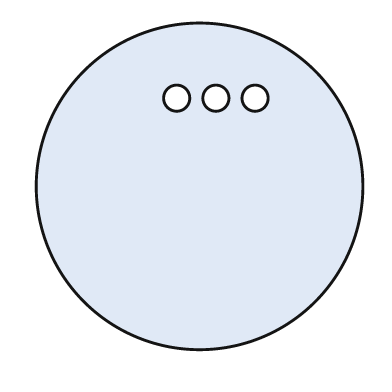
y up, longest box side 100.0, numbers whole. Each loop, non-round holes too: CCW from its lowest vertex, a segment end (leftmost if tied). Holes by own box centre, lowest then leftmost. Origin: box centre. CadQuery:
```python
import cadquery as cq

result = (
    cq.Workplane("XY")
    .moveTo(0.0, 0.0)
    .circle(50.0)
    .moveTo(-7.0, 27.0)
    .circle(4.0)
    .moveTo(5.0, 27.0)
    .circle(4.0)
    .moveTo(17.0, 27.0)
    .circle(4.0)
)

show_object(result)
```